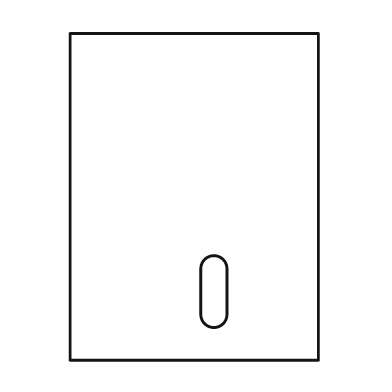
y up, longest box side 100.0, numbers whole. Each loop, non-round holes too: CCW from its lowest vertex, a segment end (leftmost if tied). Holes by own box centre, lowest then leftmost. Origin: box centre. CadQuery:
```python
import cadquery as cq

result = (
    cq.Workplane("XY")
    .moveTo(-38.0, -50.0)
    .lineTo(38.0, -50.0)
    .lineTo(38.0, 50.0)
    .lineTo(-38.0, 50.0)
    .close()
    .moveTo(2.0, -36.0)
    .threePointArc((6.0, -40.0), (10.0, -36.0))
    .lineTo(10.0, -22.0)
    .threePointArc((6.0, -18.0), (2.0, -22.0))
    .close()
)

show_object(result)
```